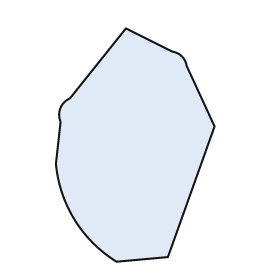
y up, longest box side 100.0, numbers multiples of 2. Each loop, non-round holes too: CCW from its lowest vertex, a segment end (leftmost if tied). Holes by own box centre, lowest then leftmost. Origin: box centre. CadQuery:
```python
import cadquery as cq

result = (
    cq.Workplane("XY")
    .moveTo(-8.0, -50.0)
    .lineTo(14.0, -48.0)
    .lineTo(34.0, 8.0)
    .lineTo(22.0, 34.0)
    .threePointArc((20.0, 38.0), (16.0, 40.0))
    .lineTo(-4.0, 50.0)
    .lineTo(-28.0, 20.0)
    .threePointArc((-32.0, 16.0), (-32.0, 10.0))
    .lineTo(-34.0, -8.0)
    .threePointArc((-26.0, -32.0), (-8.0, -50.0))
    .close()
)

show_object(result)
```